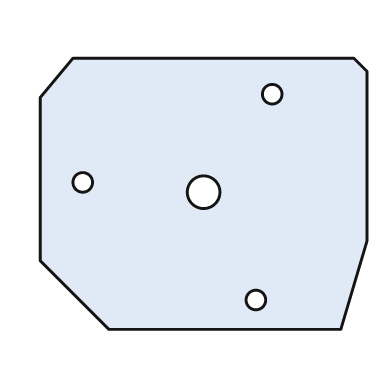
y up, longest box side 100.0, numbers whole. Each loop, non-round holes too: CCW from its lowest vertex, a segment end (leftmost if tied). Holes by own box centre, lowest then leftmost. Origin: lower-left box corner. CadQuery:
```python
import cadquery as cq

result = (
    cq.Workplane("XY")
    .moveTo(21.0, 0.0)
    .lineTo(92.0, 0.0)
    .lineTo(100.0, 27.0)
    .lineTo(100.0, 79.0)
    .lineTo(96.0, 83.0)
    .lineTo(10.0, 83.0)
    .lineTo(0.0, 71.0)
    .lineTo(0.0, 21.0)
    .close()
    .moveTo(66.0, 9.0)
    .circle(3.0)
    .moveTo(50.0, 42.0)
    .circle(5.0)
    .moveTo(13.0, 45.0)
    .circle(3.0)
    .moveTo(71.0, 72.0)
    .circle(3.0)
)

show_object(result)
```